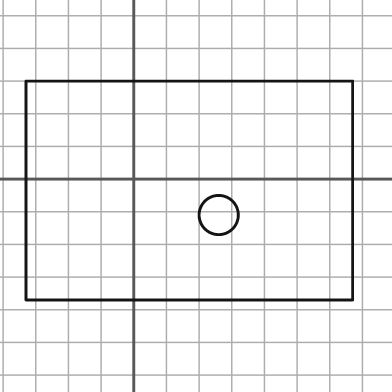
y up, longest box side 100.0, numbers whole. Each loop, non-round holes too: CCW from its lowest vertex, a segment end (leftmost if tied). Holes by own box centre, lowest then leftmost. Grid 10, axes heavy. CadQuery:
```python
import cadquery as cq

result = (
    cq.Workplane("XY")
    .moveTo(-33.0, -37.0)
    .lineTo(67.0, -37.0)
    .lineTo(67.0, 30.0)
    .lineTo(-33.0, 30.0)
    .close()
    .moveTo(26.0, -11.0)
    .circle(6.0)
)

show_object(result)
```